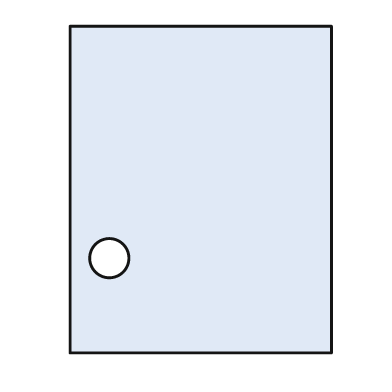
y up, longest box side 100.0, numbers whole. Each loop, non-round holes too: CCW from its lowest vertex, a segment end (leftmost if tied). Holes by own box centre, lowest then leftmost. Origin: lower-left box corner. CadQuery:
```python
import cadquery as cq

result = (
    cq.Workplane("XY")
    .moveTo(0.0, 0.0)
    .lineTo(80.0, 0.0)
    .lineTo(80.0, 100.0)
    .lineTo(0.0, 100.0)
    .close()
    .moveTo(12.0, 29.0)
    .circle(6.0)
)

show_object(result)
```